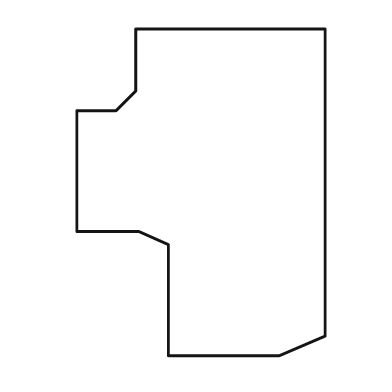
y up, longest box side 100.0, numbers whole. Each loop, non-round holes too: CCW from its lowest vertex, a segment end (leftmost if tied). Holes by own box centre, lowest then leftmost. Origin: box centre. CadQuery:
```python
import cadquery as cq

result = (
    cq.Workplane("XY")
    .moveTo(-10.0, -50.0)
    .lineTo(24.0, -50.0)
    .lineTo(38.0, -44.0)
    .lineTo(38.0, 50.0)
    .lineTo(-20.0, 50.0)
    .lineTo(-20.0, 31.0)
    .lineTo(-26.0, 25.0)
    .lineTo(-38.0, 25.0)
    .lineTo(-38.0, -12.0)
    .lineTo(-19.0, -12.0)
    .lineTo(-10.0, -16.0)
    .close()
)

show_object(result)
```